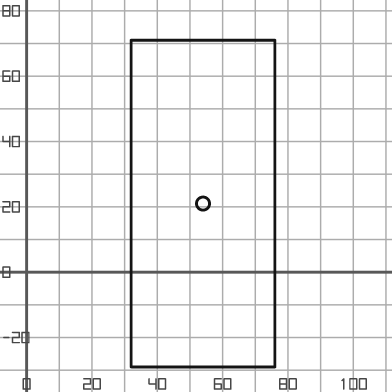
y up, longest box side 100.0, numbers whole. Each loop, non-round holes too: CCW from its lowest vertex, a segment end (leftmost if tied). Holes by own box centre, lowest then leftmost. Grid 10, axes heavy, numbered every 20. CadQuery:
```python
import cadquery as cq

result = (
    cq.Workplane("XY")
    .moveTo(32.0, -29.0)
    .lineTo(76.0, -29.0)
    .lineTo(76.0, 71.0)
    .lineTo(32.0, 71.0)
    .close()
    .moveTo(54.0, 21.0)
    .circle(2.0)
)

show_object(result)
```